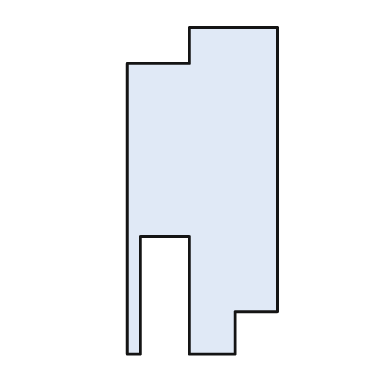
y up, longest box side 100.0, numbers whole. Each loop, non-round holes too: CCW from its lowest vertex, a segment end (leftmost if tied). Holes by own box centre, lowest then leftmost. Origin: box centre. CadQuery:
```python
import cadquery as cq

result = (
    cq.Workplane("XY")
    .moveTo(-23.0, -50.0)
    .lineTo(-19.0, -50.0)
    .lineTo(-19.0, -14.0)
    .lineTo(-4.0, -14.0)
    .lineTo(-4.0, -50.0)
    .lineTo(10.0, -50.0)
    .lineTo(10.0, -37.0)
    .lineTo(23.0, -37.0)
    .lineTo(23.0, 50.0)
    .lineTo(-4.0, 50.0)
    .lineTo(-4.0, 39.0)
    .lineTo(-23.0, 39.0)
    .close()
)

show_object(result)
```